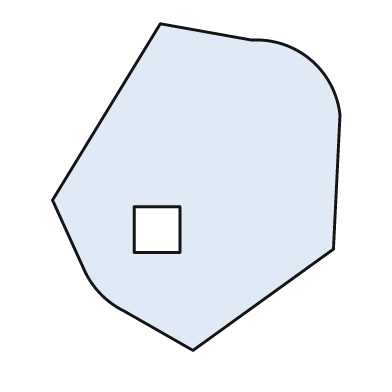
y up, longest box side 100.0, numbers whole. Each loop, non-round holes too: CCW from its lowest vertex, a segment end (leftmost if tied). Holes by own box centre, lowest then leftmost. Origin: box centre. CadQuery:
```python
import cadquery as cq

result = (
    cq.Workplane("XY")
    .moveTo(-1.0, -50.0)
    .lineTo(42.0, -19.0)
    .lineTo(44.0, 22.0)
    .threePointArc((35.0, 39.0), (17.0, 45.0))
    .lineTo(-11.0, 50.0)
    .lineTo(-44.0, -4.0)
    .lineTo(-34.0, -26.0)
    .threePointArc((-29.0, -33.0), (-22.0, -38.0))
    .close()
    .moveTo(-19.0, -20.0)
    .lineTo(-5.0, -20.0)
    .lineTo(-5.0, -6.0)
    .lineTo(-19.0, -6.0)
    .close()
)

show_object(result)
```